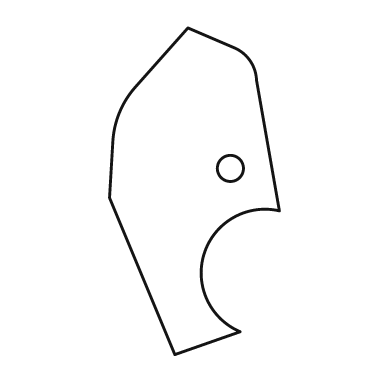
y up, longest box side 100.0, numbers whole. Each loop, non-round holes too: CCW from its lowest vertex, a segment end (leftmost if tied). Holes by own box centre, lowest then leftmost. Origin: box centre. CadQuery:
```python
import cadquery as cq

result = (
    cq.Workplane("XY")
    .moveTo(-6.0, -50.0)
    .lineTo(14.0, -43.0)
    .threePointArc((3.0, -19.0), (26.0, -6.0))
    .lineTo(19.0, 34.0)
    .threePointArc((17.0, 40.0), (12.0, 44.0))
    .lineTo(-2.0, 50.0)
    .lineTo(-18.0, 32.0)
    .threePointArc((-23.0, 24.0), (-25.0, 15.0))
    .lineTo(-26.0, -2.0)
    .close()
    .moveTo(11.0, 7.0)
    .circle(4.0)
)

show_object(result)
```